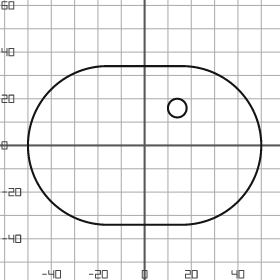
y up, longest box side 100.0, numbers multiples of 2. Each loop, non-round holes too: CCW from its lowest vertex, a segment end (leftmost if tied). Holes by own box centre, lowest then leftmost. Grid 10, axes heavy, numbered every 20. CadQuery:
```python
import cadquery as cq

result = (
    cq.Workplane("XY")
    .moveTo(-16.0, -34.0)
    .lineTo(16.0, -34.0)
    .threePointArc((50.0, 0.0), (16.0, 34.0))
    .lineTo(-16.0, 34.0)
    .threePointArc((-50.0, 0.0), (-16.0, -34.0))
    .close()
    .moveTo(14.0, 16.0)
    .circle(4.0)
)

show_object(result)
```